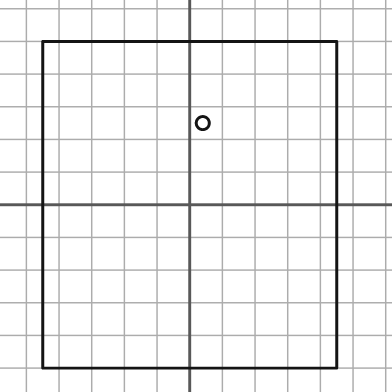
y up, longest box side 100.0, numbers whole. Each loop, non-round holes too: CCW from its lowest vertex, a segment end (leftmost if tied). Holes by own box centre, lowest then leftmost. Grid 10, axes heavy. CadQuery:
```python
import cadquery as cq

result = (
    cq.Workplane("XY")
    .moveTo(-45.0, -50.0)
    .lineTo(45.0, -50.0)
    .lineTo(45.0, 50.0)
    .lineTo(-45.0, 50.0)
    .close()
    .moveTo(4.0, 25.0)
    .circle(2.0)
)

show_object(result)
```